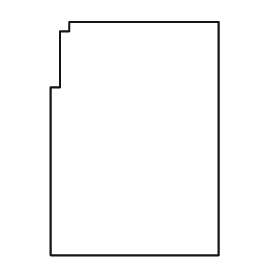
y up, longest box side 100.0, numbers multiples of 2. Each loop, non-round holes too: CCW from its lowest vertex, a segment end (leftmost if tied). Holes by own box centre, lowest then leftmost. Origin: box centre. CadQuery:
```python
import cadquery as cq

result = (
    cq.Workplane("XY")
    .moveTo(-36.0, -50.0)
    .lineTo(36.0, -50.0)
    .lineTo(36.0, 50.0)
    .lineTo(-28.0, 50.0)
    .lineTo(-28.0, 46.0)
    .lineTo(-32.0, 46.0)
    .lineTo(-32.0, 22.0)
    .lineTo(-36.0, 22.0)
    .close()
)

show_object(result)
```